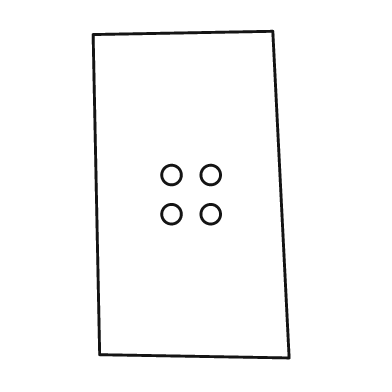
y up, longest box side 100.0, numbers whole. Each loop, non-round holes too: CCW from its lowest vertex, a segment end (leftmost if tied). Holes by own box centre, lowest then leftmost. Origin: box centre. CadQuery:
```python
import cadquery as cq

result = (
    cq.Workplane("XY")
    .moveTo(30.0, -50.0)
    .lineTo(25.0, 50.0)
    .lineTo(-30.0, 49.0)
    .lineTo(-28.0, -49.0)
    .close()
    .moveTo(-6.0, -6.0)
    .circle(3.0)
    .moveTo(6.0, -6.0)
    .circle(3.0)
    .moveTo(-6.0, 6.0)
    .circle(3.0)
    .moveTo(6.0, 6.0)
    .circle(3.0)
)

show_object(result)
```